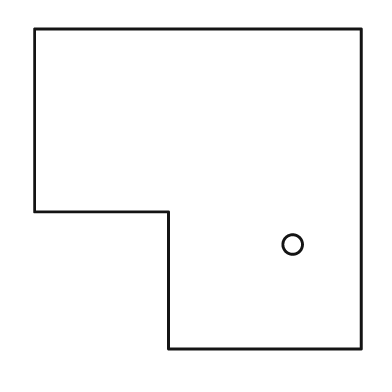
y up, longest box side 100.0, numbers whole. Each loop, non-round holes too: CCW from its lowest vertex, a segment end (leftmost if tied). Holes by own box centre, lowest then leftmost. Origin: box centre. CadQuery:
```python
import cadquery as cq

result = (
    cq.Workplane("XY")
    .moveTo(-9.0, -49.0)
    .lineTo(50.0, -49.0)
    .lineTo(50.0, 49.0)
    .lineTo(-50.0, 49.0)
    .lineTo(-50.0, -7.0)
    .lineTo(-9.0, -7.0)
    .close()
    .moveTo(29.0, -17.0)
    .circle(3.0)
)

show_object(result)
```